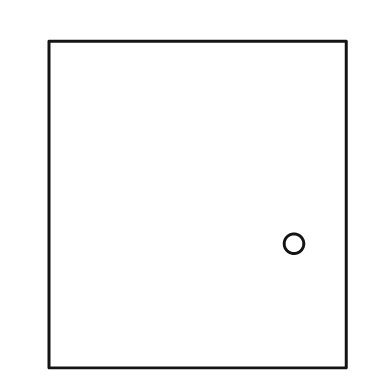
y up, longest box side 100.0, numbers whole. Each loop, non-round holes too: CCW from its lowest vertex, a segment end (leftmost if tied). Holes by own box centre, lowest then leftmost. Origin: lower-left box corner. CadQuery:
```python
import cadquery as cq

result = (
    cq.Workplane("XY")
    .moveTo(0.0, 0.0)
    .lineTo(91.0, 0.0)
    .lineTo(91.0, 100.0)
    .lineTo(0.0, 100.0)
    .close()
    .moveTo(75.0, 38.0)
    .circle(3.0)
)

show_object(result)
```